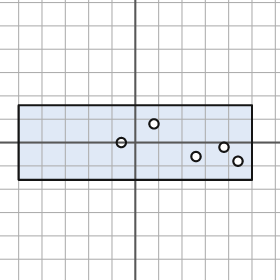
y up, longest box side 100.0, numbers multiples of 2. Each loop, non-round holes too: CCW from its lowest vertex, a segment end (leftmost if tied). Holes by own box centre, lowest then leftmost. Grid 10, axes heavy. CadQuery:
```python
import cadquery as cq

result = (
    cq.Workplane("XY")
    .moveTo(-50.0, -16.0)
    .lineTo(50.0, -16.0)
    .lineTo(50.0, 16.0)
    .lineTo(-50.0, 16.0)
    .close()
    .moveTo(44.0, -8.0)
    .circle(2.0)
    .moveTo(26.0, -6.0)
    .circle(2.0)
    .moveTo(38.0, -2.0)
    .circle(2.0)
    .moveTo(-6.0, 0.0)
    .circle(2.0)
    .moveTo(8.0, 8.0)
    .circle(2.0)
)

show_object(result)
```